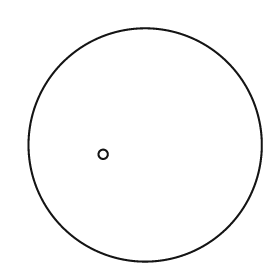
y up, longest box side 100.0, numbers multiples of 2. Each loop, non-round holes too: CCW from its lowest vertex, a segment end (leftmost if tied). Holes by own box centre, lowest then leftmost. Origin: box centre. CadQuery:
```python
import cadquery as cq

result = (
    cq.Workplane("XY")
    .moveTo(0.0, 0.0)
    .circle(50.0)
    .moveTo(-18.0, -4.0)
    .circle(2.0)
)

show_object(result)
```